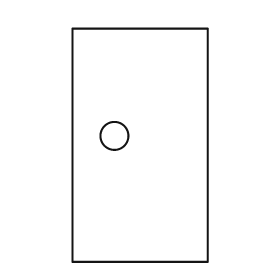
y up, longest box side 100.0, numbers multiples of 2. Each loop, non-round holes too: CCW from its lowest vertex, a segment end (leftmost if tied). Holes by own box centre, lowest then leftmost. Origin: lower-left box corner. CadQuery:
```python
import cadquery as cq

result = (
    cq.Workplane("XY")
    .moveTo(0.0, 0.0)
    .lineTo(58.0, 0.0)
    .lineTo(58.0, 100.0)
    .lineTo(0.0, 100.0)
    .close()
    .moveTo(18.0, 54.0)
    .circle(6.0)
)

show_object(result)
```